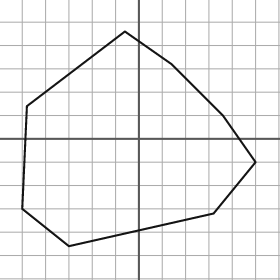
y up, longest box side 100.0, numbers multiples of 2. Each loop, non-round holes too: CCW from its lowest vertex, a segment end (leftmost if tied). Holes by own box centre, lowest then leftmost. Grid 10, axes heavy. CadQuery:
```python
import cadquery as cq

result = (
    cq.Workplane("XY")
    .moveTo(-30.0, -46.0)
    .lineTo(32.0, -32.0)
    .lineTo(50.0, -10.0)
    .lineTo(36.0, 10.0)
    .lineTo(14.0, 32.0)
    .lineTo(-6.0, 46.0)
    .lineTo(-48.0, 14.0)
    .lineTo(-50.0, -30.0)
    .close()
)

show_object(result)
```